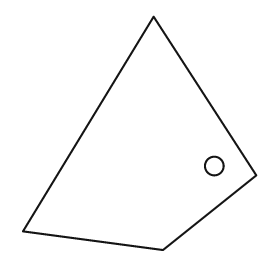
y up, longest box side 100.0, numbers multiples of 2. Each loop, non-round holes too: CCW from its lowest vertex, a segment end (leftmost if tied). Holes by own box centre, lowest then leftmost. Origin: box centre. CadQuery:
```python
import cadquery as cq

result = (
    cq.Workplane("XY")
    .moveTo(10.0, -50.0)
    .lineTo(50.0, -18.0)
    .lineTo(6.0, 50.0)
    .lineTo(-50.0, -42.0)
    .close()
    .moveTo(32.0, -14.0)
    .circle(4.0)
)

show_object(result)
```